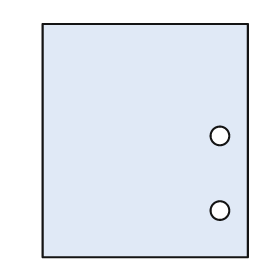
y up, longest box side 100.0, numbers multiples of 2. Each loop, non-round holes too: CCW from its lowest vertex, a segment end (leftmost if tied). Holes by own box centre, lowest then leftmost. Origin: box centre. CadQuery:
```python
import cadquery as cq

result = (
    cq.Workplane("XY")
    .moveTo(-44.0, -50.0)
    .lineTo(44.0, -50.0)
    .lineTo(44.0, 50.0)
    .lineTo(-44.0, 50.0)
    .close()
    .moveTo(32.0, -30.0)
    .circle(4.0)
    .moveTo(32.0, 2.0)
    .circle(4.0)
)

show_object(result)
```